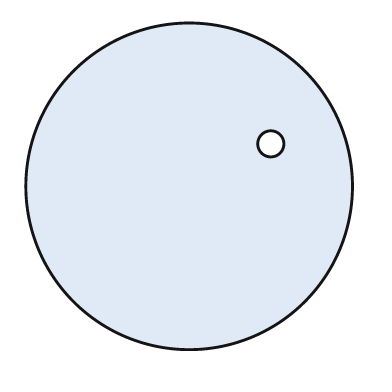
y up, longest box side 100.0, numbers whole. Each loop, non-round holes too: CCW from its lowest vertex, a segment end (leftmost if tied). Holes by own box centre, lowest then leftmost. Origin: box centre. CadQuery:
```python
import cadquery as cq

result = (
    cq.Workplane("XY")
    .moveTo(0.0, 0.0)
    .circle(50.0)
    .moveTo(25.0, 13.0)
    .circle(4.0)
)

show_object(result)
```